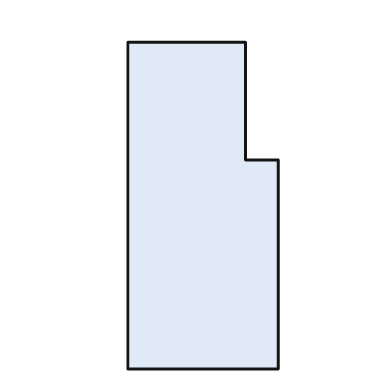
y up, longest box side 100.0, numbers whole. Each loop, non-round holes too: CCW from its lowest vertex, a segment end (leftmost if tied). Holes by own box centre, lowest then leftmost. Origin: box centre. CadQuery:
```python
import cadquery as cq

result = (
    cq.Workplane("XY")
    .moveTo(-23.0, -50.0)
    .lineTo(23.0, -50.0)
    .lineTo(23.0, 14.0)
    .lineTo(13.0, 14.0)
    .lineTo(13.0, 50.0)
    .lineTo(-23.0, 50.0)
    .close()
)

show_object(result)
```